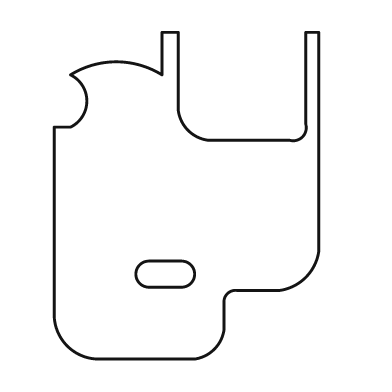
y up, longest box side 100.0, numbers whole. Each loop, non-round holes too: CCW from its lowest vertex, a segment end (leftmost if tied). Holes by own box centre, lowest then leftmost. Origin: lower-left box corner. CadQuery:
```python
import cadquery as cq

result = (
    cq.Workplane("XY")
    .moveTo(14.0, 0.0)
    .lineTo(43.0, 0.0)
    .threePointArc((49.0, 3.0), (52.0, 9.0))
    .lineTo(52.0, 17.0)
    .threePointArc((53.0, 20.0), (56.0, 21.0))
    .lineTo(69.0, 21.0)
    .threePointArc((77.0, 25.0), (81.0, 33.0))
    .lineTo(81.0, 100.0)
    .lineTo(77.0, 100.0)
    .lineTo(77.0, 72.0)
    .threePointArc((76.0, 68.0), (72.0, 67.0))
    .lineTo(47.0, 67.0)
    .threePointArc((41.0, 70.0), (38.0, 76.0))
    .lineTo(38.0, 100.0)
    .lineTo(33.0, 100.0)
    .lineTo(33.0, 87.0)
    .threePointArc((19.0, 91.0), (5.0, 87.0))
    .threePointArc((10.0, 79.0), (5.0, 71.0))
    .lineTo(0.0, 71.0)
    .lineTo(0.0, 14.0)
    .threePointArc((4.0, 4.0), (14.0, 0.0))
    .close()
    .moveTo(29.0, 22.0)
    .lineTo(39.0, 22.0)
    .threePointArc((43.0, 26.0), (39.0, 30.0))
    .lineTo(29.0, 30.0)
    .threePointArc((25.0, 26.0), (29.0, 22.0))
    .close()
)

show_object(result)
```